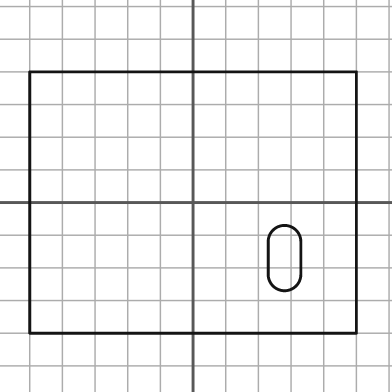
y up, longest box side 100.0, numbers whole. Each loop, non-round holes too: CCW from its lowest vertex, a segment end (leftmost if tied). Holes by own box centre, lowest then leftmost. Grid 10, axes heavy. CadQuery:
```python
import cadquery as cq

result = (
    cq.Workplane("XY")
    .moveTo(-50.0, -40.0)
    .lineTo(50.0, -40.0)
    .lineTo(50.0, 40.0)
    .lineTo(-50.0, 40.0)
    .close()
    .moveTo(23.0, -22.0)
    .threePointArc((28.0, -27.0), (33.0, -22.0))
    .lineTo(33.0, -12.0)
    .threePointArc((28.0, -7.0), (23.0, -12.0))
    .close()
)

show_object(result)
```